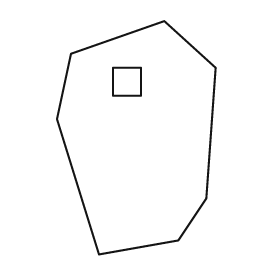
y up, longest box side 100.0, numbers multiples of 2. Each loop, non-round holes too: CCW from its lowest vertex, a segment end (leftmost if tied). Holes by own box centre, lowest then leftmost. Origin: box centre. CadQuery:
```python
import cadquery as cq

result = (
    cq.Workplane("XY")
    .moveTo(-16.0, -50.0)
    .lineTo(18.0, -44.0)
    .lineTo(30.0, -26.0)
    .lineTo(34.0, 30.0)
    .lineTo(12.0, 50.0)
    .lineTo(-28.0, 36.0)
    .lineTo(-34.0, 8.0)
    .close()
    .moveTo(-10.0, 18.0)
    .lineTo(2.0, 18.0)
    .lineTo(2.0, 30.0)
    .lineTo(-10.0, 30.0)
    .close()
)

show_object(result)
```